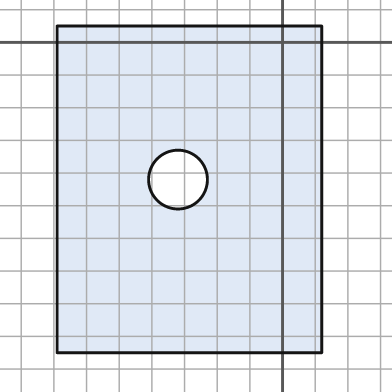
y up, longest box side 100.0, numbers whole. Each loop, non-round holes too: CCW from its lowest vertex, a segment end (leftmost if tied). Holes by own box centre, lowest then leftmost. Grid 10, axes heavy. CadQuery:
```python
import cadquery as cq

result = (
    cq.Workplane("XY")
    .moveTo(-69.0, -95.0)
    .lineTo(12.0, -95.0)
    .lineTo(12.0, 5.0)
    .lineTo(-69.0, 5.0)
    .close()
    .moveTo(-32.0, -42.0)
    .circle(9.0)
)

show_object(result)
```